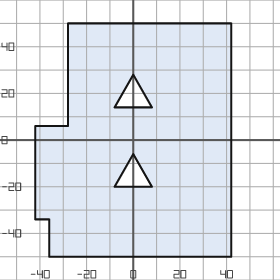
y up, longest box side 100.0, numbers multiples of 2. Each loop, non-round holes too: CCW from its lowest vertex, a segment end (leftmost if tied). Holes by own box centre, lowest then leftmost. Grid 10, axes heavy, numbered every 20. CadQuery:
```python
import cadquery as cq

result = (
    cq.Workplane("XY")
    .moveTo(-36.0, -50.0)
    .lineTo(42.0, -50.0)
    .lineTo(42.0, 50.0)
    .lineTo(-28.0, 50.0)
    .lineTo(-28.0, 6.0)
    .lineTo(-42.0, 6.0)
    .lineTo(-42.0, -34.0)
    .lineTo(-36.0, -34.0)
    .close()
    .moveTo(-8.0, -20.0)
    .lineTo(8.0, -20.0)
    .lineTo(0.0, -6.0)
    .close()
    .moveTo(-8.0, 14.0)
    .lineTo(8.0, 14.0)
    .lineTo(0.0, 28.0)
    .close()
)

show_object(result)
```